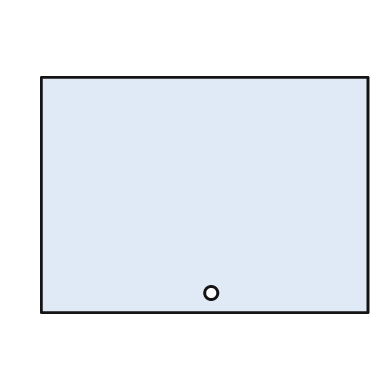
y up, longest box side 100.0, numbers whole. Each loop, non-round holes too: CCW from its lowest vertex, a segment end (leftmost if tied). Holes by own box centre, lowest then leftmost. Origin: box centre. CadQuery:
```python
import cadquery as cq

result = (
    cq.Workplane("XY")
    .moveTo(-50.0, -36.0)
    .lineTo(50.0, -36.0)
    .lineTo(50.0, 36.0)
    .lineTo(-50.0, 36.0)
    .close()
    .moveTo(2.0, -30.0)
    .circle(2.0)
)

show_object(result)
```